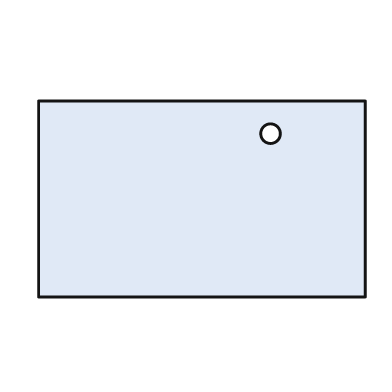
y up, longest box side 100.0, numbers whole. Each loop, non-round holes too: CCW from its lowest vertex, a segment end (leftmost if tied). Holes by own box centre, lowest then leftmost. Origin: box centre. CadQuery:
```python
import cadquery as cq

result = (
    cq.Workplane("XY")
    .moveTo(-50.0, -30.0)
    .lineTo(50.0, -30.0)
    .lineTo(50.0, 30.0)
    .lineTo(-50.0, 30.0)
    .close()
    .moveTo(21.0, 20.0)
    .circle(3.0)
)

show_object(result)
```